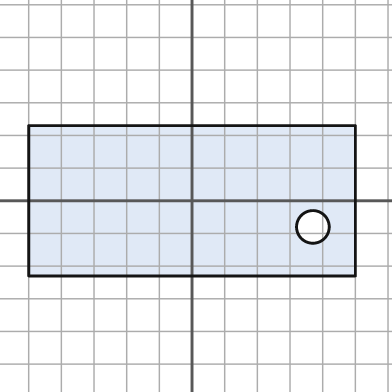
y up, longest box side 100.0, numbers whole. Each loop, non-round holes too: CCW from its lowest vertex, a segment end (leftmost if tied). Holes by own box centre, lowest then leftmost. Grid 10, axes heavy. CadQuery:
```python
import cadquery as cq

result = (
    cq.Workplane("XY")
    .moveTo(-50.0, -23.0)
    .lineTo(50.0, -23.0)
    .lineTo(50.0, 23.0)
    .lineTo(-50.0, 23.0)
    .close()
    .moveTo(37.0, -8.0)
    .circle(5.0)
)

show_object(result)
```